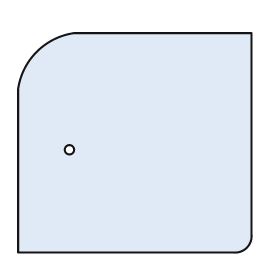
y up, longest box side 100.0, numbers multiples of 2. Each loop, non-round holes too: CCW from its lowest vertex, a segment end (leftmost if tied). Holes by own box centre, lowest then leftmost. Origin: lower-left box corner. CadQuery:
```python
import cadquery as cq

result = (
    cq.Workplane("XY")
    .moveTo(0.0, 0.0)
    .lineTo(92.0, 0.0)
    .threePointArc((98.0, 2.0), (100.0, 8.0))
    .lineTo(100.0, 94.0)
    .lineTo(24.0, 94.0)
    .threePointArc((8.0, 86.0), (0.0, 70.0))
    .close()
    .moveTo(22.0, 44.0)
    .circle(2.0)
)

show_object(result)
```